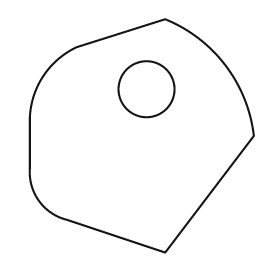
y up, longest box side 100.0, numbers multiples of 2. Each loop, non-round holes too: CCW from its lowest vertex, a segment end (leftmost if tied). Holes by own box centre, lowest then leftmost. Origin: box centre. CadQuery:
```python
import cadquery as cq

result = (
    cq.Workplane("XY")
    .moveTo(10.0, -50.0)
    .lineTo(48.0, 0.0)
    .threePointArc((36.0, 30.0), (10.0, 50.0))
    .lineTo(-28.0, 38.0)
    .threePointArc((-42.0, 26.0), (-48.0, 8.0))
    .lineTo(-48.0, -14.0)
    .threePointArc((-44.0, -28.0), (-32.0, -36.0))
    .close()
    .moveTo(2.0, 20.0)
    .circle(12.0)
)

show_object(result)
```